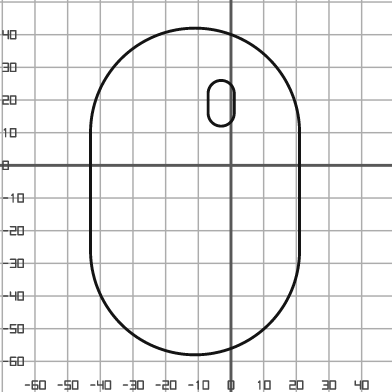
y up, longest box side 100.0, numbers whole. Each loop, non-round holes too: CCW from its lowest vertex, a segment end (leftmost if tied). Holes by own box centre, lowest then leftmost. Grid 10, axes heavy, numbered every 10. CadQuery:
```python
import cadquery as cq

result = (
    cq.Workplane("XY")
    .moveTo(-43.0, -26.0)
    .threePointArc((-11.0, -58.0), (21.0, -26.0))
    .lineTo(21.0, 10.0)
    .threePointArc((-11.0, 42.0), (-43.0, 10.0))
    .close()
    .moveTo(-7.0, 16.0)
    .threePointArc((-3.0, 12.0), (1.0, 16.0))
    .lineTo(1.0, 22.0)
    .threePointArc((-3.0, 26.0), (-7.0, 22.0))
    .close()
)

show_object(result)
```